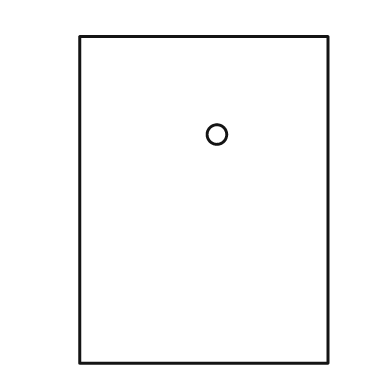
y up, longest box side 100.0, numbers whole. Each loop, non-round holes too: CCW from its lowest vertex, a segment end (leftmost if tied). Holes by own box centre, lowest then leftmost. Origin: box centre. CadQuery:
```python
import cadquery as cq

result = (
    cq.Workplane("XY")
    .moveTo(-38.0, -50.0)
    .lineTo(38.0, -50.0)
    .lineTo(38.0, 50.0)
    .lineTo(-38.0, 50.0)
    .close()
    .moveTo(4.0, 20.0)
    .circle(3.0)
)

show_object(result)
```